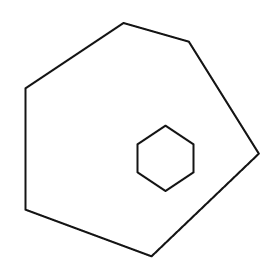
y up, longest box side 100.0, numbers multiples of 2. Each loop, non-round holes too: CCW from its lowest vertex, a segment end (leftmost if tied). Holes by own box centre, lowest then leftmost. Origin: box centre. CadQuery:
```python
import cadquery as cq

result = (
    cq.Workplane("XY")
    .moveTo(4.0, -50.0)
    .lineTo(50.0, -6.0)
    .lineTo(20.0, 42.0)
    .lineTo(-8.0, 50.0)
    .lineTo(-50.0, 22.0)
    .lineTo(-50.0, -30.0)
    .close()
    .moveTo(10.0, -22.0)
    .lineTo(22.0, -14.0)
    .lineTo(22.0, -2.0)
    .lineTo(10.0, 6.0)
    .lineTo(-2.0, -2.0)
    .lineTo(-2.0, -14.0)
    .close()
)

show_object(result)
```